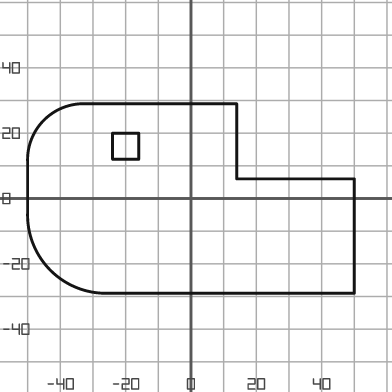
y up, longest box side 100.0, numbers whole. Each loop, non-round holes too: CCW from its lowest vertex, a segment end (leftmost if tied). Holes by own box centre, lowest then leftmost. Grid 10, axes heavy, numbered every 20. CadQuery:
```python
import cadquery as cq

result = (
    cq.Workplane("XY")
    .moveTo(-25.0, -29.0)
    .lineTo(50.0, -29.0)
    .lineTo(50.0, 6.0)
    .lineTo(14.0, 6.0)
    .lineTo(14.0, 29.0)
    .lineTo(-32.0, 29.0)
    .threePointArc((-45.0, 24.0), (-50.0, 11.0))
    .lineTo(-50.0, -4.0)
    .threePointArc((-43.0, -22.0), (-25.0, -29.0))
    .close()
    .moveTo(-24.0, 12.0)
    .lineTo(-16.0, 12.0)
    .lineTo(-16.0, 20.0)
    .lineTo(-24.0, 20.0)
    .close()
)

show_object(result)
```